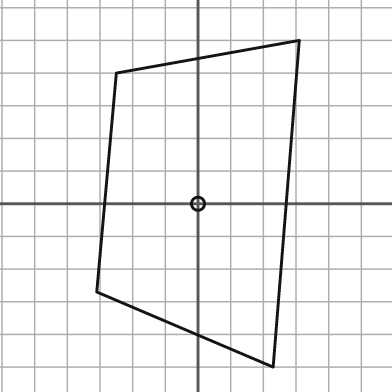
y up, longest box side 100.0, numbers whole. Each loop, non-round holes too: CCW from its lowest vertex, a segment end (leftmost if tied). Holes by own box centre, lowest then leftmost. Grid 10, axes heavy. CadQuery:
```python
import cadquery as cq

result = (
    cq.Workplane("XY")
    .moveTo(23.0, -50.0)
    .lineTo(31.0, 50.0)
    .lineTo(-25.0, 40.0)
    .lineTo(-31.0, -27.0)
    .close()
    .moveTo(0.0, 0.0)
    .circle(2.0)
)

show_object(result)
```